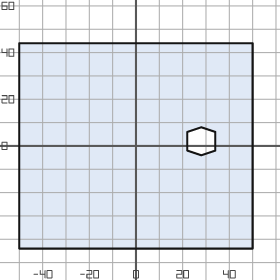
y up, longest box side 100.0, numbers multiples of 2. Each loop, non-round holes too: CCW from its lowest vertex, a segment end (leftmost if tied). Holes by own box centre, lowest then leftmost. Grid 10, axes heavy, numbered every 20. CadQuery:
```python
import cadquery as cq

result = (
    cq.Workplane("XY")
    .moveTo(-50.0, -44.0)
    .lineTo(50.0, -44.0)
    .lineTo(50.0, 44.0)
    .lineTo(-50.0, 44.0)
    .close()
    .moveTo(28.0, -4.0)
    .lineTo(34.0, -2.0)
    .lineTo(34.0, 6.0)
    .lineTo(28.0, 8.0)
    .lineTo(22.0, 6.0)
    .lineTo(22.0, -2.0)
    .close()
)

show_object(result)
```